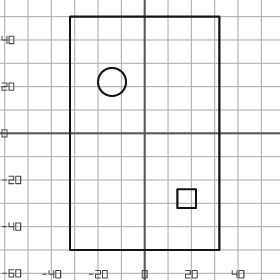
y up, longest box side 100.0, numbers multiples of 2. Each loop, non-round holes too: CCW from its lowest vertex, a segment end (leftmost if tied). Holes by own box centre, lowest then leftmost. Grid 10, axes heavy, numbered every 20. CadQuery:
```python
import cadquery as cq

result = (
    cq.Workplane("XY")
    .moveTo(-32.0, -50.0)
    .lineTo(32.0, -50.0)
    .lineTo(32.0, 50.0)
    .lineTo(-32.0, 50.0)
    .close()
    .moveTo(14.0, -32.0)
    .lineTo(22.0, -32.0)
    .lineTo(22.0, -24.0)
    .lineTo(14.0, -24.0)
    .close()
    .moveTo(-14.0, 22.0)
    .circle(6.0)
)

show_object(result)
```